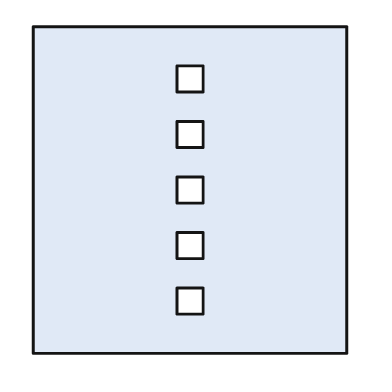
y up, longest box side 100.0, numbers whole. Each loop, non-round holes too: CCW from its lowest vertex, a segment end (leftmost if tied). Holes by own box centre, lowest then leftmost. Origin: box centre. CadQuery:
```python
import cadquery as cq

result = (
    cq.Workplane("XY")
    .moveTo(-48.0, -50.0)
    .lineTo(48.0, -50.0)
    .lineTo(48.0, 50.0)
    .lineTo(-48.0, 50.0)
    .close()
    .moveTo(-4.0, -38.0)
    .lineTo(4.0, -38.0)
    .lineTo(4.0, -30.0)
    .lineTo(-4.0, -30.0)
    .close()
    .moveTo(-4.0, -21.0)
    .lineTo(4.0, -21.0)
    .lineTo(4.0, -13.0)
    .lineTo(-4.0, -13.0)
    .close()
    .moveTo(-4.0, -4.0)
    .lineTo(4.0, -4.0)
    .lineTo(4.0, 4.0)
    .lineTo(-4.0, 4.0)
    .close()
    .moveTo(-4.0, 13.0)
    .lineTo(4.0, 13.0)
    .lineTo(4.0, 21.0)
    .lineTo(-4.0, 21.0)
    .close()
    .moveTo(-4.0, 30.0)
    .lineTo(4.0, 30.0)
    .lineTo(4.0, 38.0)
    .lineTo(-4.0, 38.0)
    .close()
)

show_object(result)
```